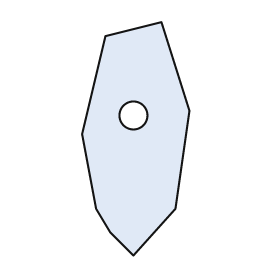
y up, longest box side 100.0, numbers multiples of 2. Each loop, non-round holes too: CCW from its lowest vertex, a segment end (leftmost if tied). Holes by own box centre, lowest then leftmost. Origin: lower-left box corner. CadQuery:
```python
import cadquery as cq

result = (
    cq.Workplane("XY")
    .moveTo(22.0, 0.0)
    .lineTo(40.0, 20.0)
    .lineTo(46.0, 62.0)
    .lineTo(34.0, 100.0)
    .lineTo(10.0, 94.0)
    .lineTo(0.0, 52.0)
    .lineTo(6.0, 20.0)
    .lineTo(12.0, 10.0)
    .close()
    .moveTo(22.0, 60.0)
    .circle(6.0)
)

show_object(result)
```